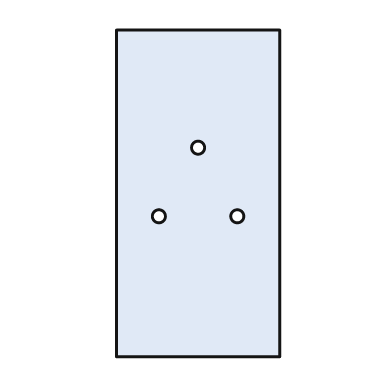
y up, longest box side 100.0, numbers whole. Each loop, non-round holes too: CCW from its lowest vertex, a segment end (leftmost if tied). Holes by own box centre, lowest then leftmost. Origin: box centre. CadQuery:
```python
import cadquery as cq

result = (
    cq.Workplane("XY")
    .moveTo(-25.0, -50.0)
    .lineTo(25.0, -50.0)
    .lineTo(25.0, 50.0)
    .lineTo(-25.0, 50.0)
    .close()
    .moveTo(-12.0, -7.0)
    .circle(2.0)
    .moveTo(12.0, -7.0)
    .circle(2.0)
    .moveTo(0.0, 14.0)
    .circle(2.0)
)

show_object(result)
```